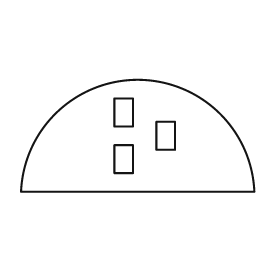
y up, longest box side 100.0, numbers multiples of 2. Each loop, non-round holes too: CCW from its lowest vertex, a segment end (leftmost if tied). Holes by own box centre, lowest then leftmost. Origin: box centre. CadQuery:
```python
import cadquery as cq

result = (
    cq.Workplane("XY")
    .moveTo(-50.0, -24.0)
    .lineTo(50.0, -24.0)
    .threePointArc((0.0, 24.0), (-50.0, -24.0))
    .close()
    .moveTo(-10.0, -16.0)
    .lineTo(-2.0, -16.0)
    .lineTo(-2.0, -4.0)
    .lineTo(-10.0, -4.0)
    .close()
    .moveTo(8.0, -6.0)
    .lineTo(16.0, -6.0)
    .lineTo(16.0, 6.0)
    .lineTo(8.0, 6.0)
    .close()
    .moveTo(-10.0, 4.0)
    .lineTo(-2.0, 4.0)
    .lineTo(-2.0, 16.0)
    .lineTo(-10.0, 16.0)
    .close()
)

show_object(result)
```